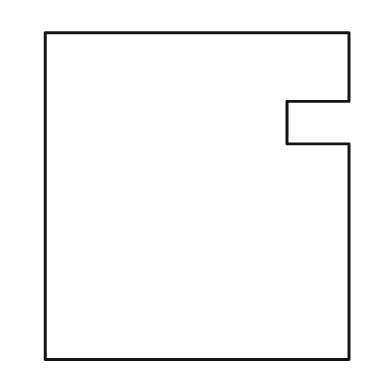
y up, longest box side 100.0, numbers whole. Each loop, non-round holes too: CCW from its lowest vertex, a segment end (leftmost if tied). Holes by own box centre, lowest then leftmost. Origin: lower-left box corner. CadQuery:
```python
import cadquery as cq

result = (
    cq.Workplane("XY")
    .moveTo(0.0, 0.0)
    .lineTo(93.0, 0.0)
    .lineTo(93.0, 66.0)
    .lineTo(74.0, 66.0)
    .lineTo(74.0, 79.0)
    .lineTo(93.0, 79.0)
    .lineTo(93.0, 100.0)
    .lineTo(0.0, 100.0)
    .close()
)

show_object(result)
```